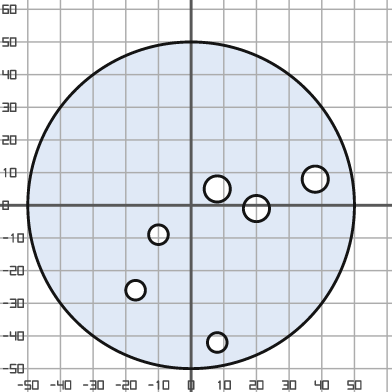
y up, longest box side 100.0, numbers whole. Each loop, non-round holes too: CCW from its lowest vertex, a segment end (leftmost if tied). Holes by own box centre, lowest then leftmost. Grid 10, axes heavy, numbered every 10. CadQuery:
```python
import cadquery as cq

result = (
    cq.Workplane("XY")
    .moveTo(0.0, 0.0)
    .circle(50.0)
    .moveTo(8.0, -42.0)
    .circle(3.0)
    .moveTo(-17.0, -26.0)
    .circle(3.0)
    .moveTo(-10.0, -9.0)
    .circle(3.0)
    .moveTo(20.0, -1.0)
    .circle(4.0)
    .moveTo(8.0, 5.0)
    .circle(4.0)
    .moveTo(38.0, 8.0)
    .circle(4.0)
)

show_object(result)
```